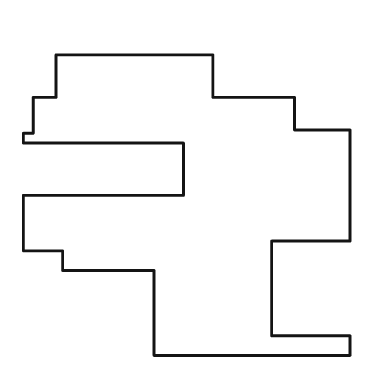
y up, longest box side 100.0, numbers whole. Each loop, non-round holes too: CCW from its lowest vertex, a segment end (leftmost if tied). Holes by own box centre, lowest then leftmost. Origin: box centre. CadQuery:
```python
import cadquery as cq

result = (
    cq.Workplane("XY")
    .moveTo(-10.0, -46.0)
    .lineTo(50.0, -46.0)
    .lineTo(50.0, -40.0)
    .lineTo(26.0, -40.0)
    .lineTo(26.0, -11.0)
    .lineTo(50.0, -11.0)
    .lineTo(50.0, 23.0)
    .lineTo(33.0, 23.0)
    .lineTo(33.0, 33.0)
    .lineTo(8.0, 33.0)
    .lineTo(8.0, 46.0)
    .lineTo(-40.0, 46.0)
    .lineTo(-40.0, 33.0)
    .lineTo(-47.0, 33.0)
    .lineTo(-47.0, 22.0)
    .lineTo(-50.0, 22.0)
    .lineTo(-50.0, 19.0)
    .lineTo(-1.0, 19.0)
    .lineTo(-1.0, 3.0)
    .lineTo(-50.0, 3.0)
    .lineTo(-50.0, -14.0)
    .lineTo(-38.0, -14.0)
    .lineTo(-38.0, -20.0)
    .lineTo(-10.0, -20.0)
    .close()
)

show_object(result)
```